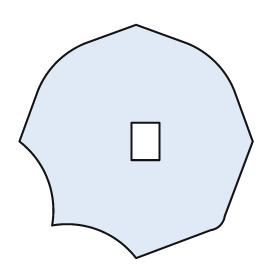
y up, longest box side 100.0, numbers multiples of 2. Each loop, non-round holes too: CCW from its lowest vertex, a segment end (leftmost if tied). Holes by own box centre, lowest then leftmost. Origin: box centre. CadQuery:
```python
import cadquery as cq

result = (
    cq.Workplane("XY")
    .moveTo(0.0, -50.0)
    .lineTo(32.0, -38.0)
    .threePointArc((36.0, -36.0), (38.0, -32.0))
    .lineTo(50.0, 0.0)
    .lineTo(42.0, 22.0)
    .threePointArc((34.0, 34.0), (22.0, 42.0))
    .lineTo(0.0, 50.0)
    .lineTo(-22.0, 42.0)
    .threePointArc((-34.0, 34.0), (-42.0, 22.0))
    .lineTo(-50.0, 0.0)
    .threePointArc((-38.0, -16.0), (-36.0, -36.0))
    .threePointArc((-16.0, -38.0), (0.0, -50.0))
    .close()
    .moveTo(-2.0, -8.0)
    .lineTo(10.0, -8.0)
    .lineTo(10.0, 8.0)
    .lineTo(-2.0, 8.0)
    .close()
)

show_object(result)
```